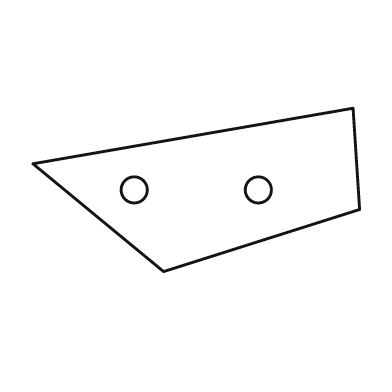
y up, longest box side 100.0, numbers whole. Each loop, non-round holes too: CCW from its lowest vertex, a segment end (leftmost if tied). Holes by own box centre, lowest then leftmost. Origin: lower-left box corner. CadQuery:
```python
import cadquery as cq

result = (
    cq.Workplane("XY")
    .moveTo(40.0, 0.0)
    .lineTo(100.0, 19.0)
    .lineTo(98.0, 50.0)
    .lineTo(0.0, 33.0)
    .close()
    .moveTo(31.0, 25.0)
    .circle(4.0)
    .moveTo(69.0, 25.0)
    .circle(4.0)
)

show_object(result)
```